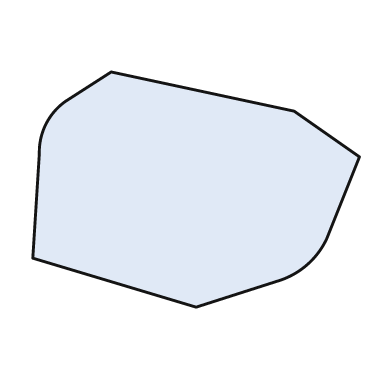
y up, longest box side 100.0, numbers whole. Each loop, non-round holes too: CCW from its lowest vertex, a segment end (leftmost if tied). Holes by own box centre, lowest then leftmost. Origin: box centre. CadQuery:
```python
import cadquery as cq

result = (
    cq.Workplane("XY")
    .moveTo(0.0, -36.0)
    .lineTo(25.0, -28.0)
    .threePointArc((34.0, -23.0), (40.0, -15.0))
    .lineTo(50.0, 10.0)
    .lineTo(30.0, 24.0)
    .lineTo(-26.0, 36.0)
    .lineTo(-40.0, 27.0)
    .threePointArc((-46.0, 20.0), (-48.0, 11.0))
    .lineTo(-50.0, -21.0)
    .close()
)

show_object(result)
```